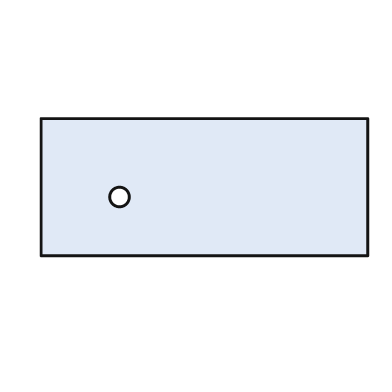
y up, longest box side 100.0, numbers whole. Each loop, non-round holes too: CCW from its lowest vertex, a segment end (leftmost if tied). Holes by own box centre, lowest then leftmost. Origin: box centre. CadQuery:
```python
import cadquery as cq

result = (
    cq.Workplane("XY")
    .moveTo(-50.0, -21.0)
    .lineTo(50.0, -21.0)
    .lineTo(50.0, 21.0)
    .lineTo(-50.0, 21.0)
    .close()
    .moveTo(-26.0, -3.0)
    .circle(3.0)
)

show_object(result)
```